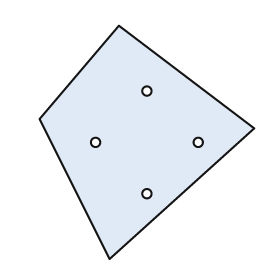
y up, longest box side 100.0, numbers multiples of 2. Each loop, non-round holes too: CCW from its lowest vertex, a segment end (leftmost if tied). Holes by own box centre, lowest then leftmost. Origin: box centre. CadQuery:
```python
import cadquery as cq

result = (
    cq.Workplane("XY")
    .moveTo(-16.0, -50.0)
    .lineTo(46.0, 6.0)
    .lineTo(-12.0, 50.0)
    .lineTo(-46.0, 10.0)
    .close()
    .moveTo(0.0, -22.0)
    .circle(2.0)
    .moveTo(-22.0, 0.0)
    .circle(2.0)
    .moveTo(22.0, 0.0)
    .circle(2.0)
    .moveTo(0.0, 22.0)
    .circle(2.0)
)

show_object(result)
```